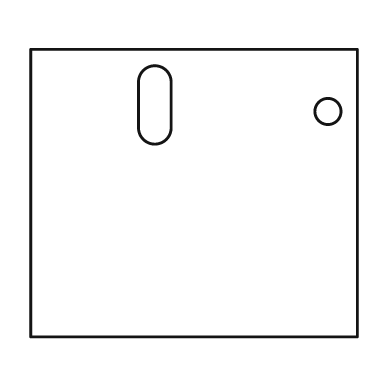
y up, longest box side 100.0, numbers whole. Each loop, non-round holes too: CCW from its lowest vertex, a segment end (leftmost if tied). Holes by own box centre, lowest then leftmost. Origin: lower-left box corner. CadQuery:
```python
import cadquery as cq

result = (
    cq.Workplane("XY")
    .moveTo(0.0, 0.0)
    .lineTo(100.0, 0.0)
    .lineTo(100.0, 88.0)
    .lineTo(0.0, 88.0)
    .close()
    .moveTo(91.0, 69.0)
    .circle(4.0)
    .moveTo(33.0, 64.0)
    .threePointArc((38.0, 59.0), (43.0, 64.0))
    .lineTo(43.0, 78.0)
    .threePointArc((38.0, 83.0), (33.0, 78.0))
    .close()
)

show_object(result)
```